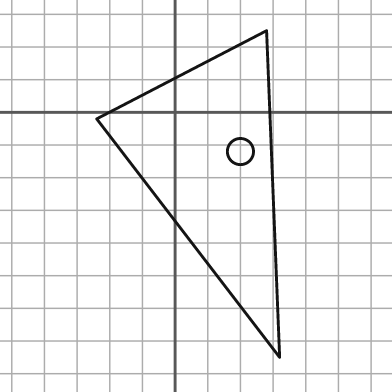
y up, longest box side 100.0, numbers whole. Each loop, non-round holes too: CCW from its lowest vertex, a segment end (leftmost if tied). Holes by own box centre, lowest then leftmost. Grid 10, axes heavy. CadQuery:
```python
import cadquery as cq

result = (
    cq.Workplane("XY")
    .moveTo(32.0, -75.0)
    .lineTo(28.0, 25.0)
    .lineTo(-24.0, -2.0)
    .close()
    .moveTo(20.0, -12.0)
    .circle(4.0)
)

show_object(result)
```